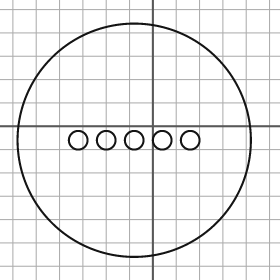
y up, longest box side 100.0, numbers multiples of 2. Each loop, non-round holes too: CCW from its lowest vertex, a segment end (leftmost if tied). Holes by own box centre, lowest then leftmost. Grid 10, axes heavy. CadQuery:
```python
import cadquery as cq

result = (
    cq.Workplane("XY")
    .moveTo(-8.0, -6.0)
    .circle(50.0)
    .moveTo(-32.0, -6.0)
    .circle(4.0)
    .moveTo(-20.0, -6.0)
    .circle(4.0)
    .moveTo(-8.0, -6.0)
    .circle(4.0)
    .moveTo(4.0, -6.0)
    .circle(4.0)
    .moveTo(16.0, -6.0)
    .circle(4.0)
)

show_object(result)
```